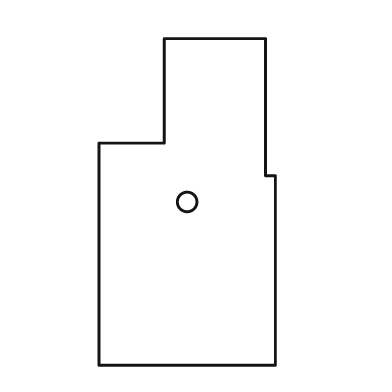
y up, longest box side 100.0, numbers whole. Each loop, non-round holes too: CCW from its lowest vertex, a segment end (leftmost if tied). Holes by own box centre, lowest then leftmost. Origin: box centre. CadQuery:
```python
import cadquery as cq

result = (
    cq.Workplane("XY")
    .moveTo(-27.0, -50.0)
    .lineTo(27.0, -50.0)
    .lineTo(27.0, 8.0)
    .lineTo(24.0, 8.0)
    .lineTo(24.0, 50.0)
    .lineTo(-7.0, 50.0)
    .lineTo(-7.0, 18.0)
    .lineTo(-27.0, 18.0)
    .close()
    .moveTo(0.0, 0.0)
    .circle(3.0)
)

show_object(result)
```